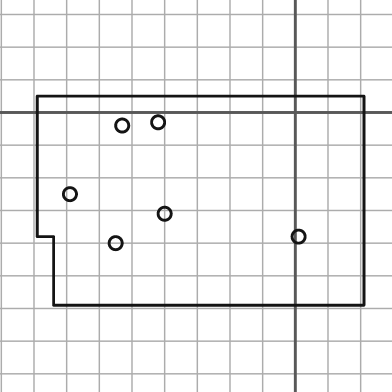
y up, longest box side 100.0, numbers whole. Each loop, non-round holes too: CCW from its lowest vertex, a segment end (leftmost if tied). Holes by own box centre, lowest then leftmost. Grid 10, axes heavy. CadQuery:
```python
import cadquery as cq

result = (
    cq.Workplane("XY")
    .moveTo(-74.0, -59.0)
    .lineTo(21.0, -59.0)
    .lineTo(21.0, 5.0)
    .lineTo(-79.0, 5.0)
    .lineTo(-79.0, -38.0)
    .lineTo(-74.0, -38.0)
    .close()
    .moveTo(-55.0, -40.0)
    .circle(2.0)
    .moveTo(1.0, -38.0)
    .circle(2.0)
    .moveTo(-40.0, -31.0)
    .circle(2.0)
    .moveTo(-69.0, -25.0)
    .circle(2.0)
    .moveTo(-53.0, -4.0)
    .circle(2.0)
    .moveTo(-42.0, -3.0)
    .circle(2.0)
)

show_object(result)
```